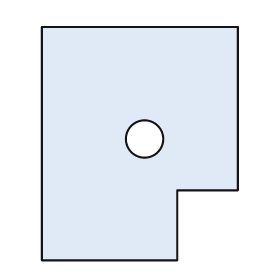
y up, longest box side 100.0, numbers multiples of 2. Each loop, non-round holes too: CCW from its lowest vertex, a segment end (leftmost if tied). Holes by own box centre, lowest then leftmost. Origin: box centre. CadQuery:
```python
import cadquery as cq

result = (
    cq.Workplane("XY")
    .moveTo(-42.0, -50.0)
    .lineTo(16.0, -50.0)
    .lineTo(16.0, -20.0)
    .lineTo(42.0, -20.0)
    .lineTo(42.0, 50.0)
    .lineTo(-42.0, 50.0)
    .close()
    .moveTo(2.0, 2.0)
    .circle(8.0)
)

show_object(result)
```